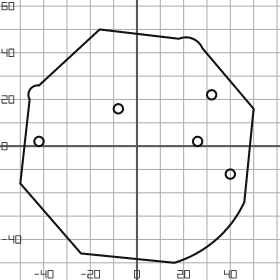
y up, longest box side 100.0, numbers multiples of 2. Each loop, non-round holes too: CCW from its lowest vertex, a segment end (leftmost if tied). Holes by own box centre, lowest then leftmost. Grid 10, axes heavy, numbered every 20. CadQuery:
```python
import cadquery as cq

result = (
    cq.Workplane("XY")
    .moveTo(16.0, -50.0)
    .threePointArc((34.0, -40.0), (46.0, -24.0))
    .lineTo(50.0, 16.0)
    .lineTo(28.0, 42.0)
    .threePointArc((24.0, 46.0), (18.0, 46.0))
    .lineTo(-16.0, 50.0)
    .lineTo(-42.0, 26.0)
    .threePointArc((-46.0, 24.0), (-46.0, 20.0))
    .lineTo(-50.0, -16.0)
    .lineTo(-24.0, -46.0)
    .close()
    .moveTo(40.0, -12.0)
    .circle(2.0)
    .moveTo(-42.0, 2.0)
    .circle(2.0)
    .moveTo(26.0, 2.0)
    .circle(2.0)
    .moveTo(-8.0, 16.0)
    .circle(2.0)
    .moveTo(32.0, 22.0)
    .circle(2.0)
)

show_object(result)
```